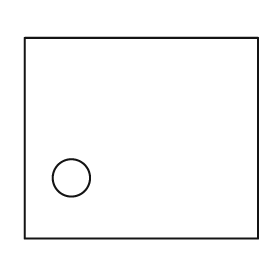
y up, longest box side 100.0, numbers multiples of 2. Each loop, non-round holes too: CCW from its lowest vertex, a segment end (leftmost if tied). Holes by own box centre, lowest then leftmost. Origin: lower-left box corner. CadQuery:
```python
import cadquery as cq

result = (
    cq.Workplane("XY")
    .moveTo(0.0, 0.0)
    .lineTo(100.0, 0.0)
    .lineTo(100.0, 86.0)
    .lineTo(0.0, 86.0)
    .close()
    .moveTo(20.0, 26.0)
    .circle(8.0)
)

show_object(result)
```